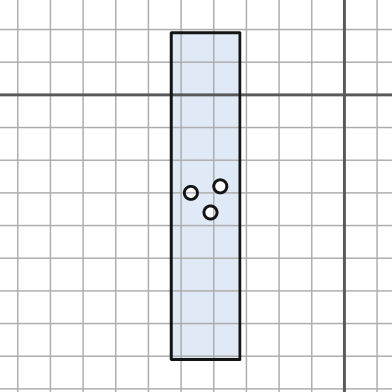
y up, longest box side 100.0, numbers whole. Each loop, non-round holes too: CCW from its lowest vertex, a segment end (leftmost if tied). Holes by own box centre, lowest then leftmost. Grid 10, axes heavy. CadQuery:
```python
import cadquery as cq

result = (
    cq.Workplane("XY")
    .moveTo(-53.0, -81.0)
    .lineTo(-32.0, -81.0)
    .lineTo(-32.0, 19.0)
    .lineTo(-53.0, 19.0)
    .close()
    .moveTo(-41.0, -36.0)
    .circle(2.0)
    .moveTo(-47.0, -30.0)
    .circle(2.0)
    .moveTo(-38.0, -28.0)
    .circle(2.0)
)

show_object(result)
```